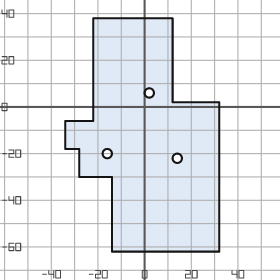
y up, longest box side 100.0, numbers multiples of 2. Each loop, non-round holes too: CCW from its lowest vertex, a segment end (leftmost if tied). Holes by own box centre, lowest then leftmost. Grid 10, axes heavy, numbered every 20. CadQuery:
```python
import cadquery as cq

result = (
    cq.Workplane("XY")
    .moveTo(-14.0, -62.0)
    .lineTo(32.0, -62.0)
    .lineTo(32.0, 2.0)
    .lineTo(12.0, 2.0)
    .lineTo(12.0, 38.0)
    .lineTo(-22.0, 38.0)
    .lineTo(-22.0, -6.0)
    .lineTo(-34.0, -6.0)
    .lineTo(-34.0, -18.0)
    .lineTo(-28.0, -18.0)
    .lineTo(-28.0, -30.0)
    .lineTo(-14.0, -30.0)
    .close()
    .moveTo(14.0, -22.0)
    .circle(2.0)
    .moveTo(-16.0, -20.0)
    .circle(2.0)
    .moveTo(2.0, 6.0)
    .circle(2.0)
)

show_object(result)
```